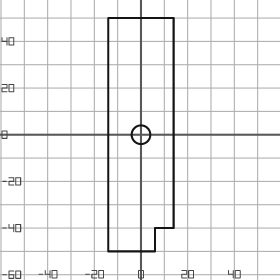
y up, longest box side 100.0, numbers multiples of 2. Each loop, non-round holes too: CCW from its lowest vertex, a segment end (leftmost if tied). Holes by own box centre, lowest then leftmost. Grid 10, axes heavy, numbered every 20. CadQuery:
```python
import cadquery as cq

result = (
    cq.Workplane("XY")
    .moveTo(-14.0, -50.0)
    .lineTo(6.0, -50.0)
    .lineTo(6.0, -40.0)
    .lineTo(14.0, -40.0)
    .lineTo(14.0, 50.0)
    .lineTo(-14.0, 50.0)
    .close()
    .moveTo(0.0, 0.0)
    .circle(4.0)
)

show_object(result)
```